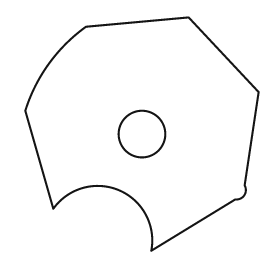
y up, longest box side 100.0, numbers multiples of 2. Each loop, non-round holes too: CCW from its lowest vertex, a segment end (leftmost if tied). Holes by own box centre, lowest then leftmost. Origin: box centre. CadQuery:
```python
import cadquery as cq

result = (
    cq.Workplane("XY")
    .moveTo(4.0, -50.0)
    .lineTo(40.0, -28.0)
    .threePointArc((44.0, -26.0), (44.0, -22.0))
    .lineTo(50.0, 18.0)
    .lineTo(20.0, 50.0)
    .lineTo(-24.0, 46.0)
    .threePointArc((-40.0, 30.0), (-50.0, 10.0))
    .lineTo(-38.0, -32.0)
    .threePointArc((-10.0, -24.0), (4.0, -50.0))
    .close()
    .moveTo(0.0, 0.0)
    .circle(10.0)
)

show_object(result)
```